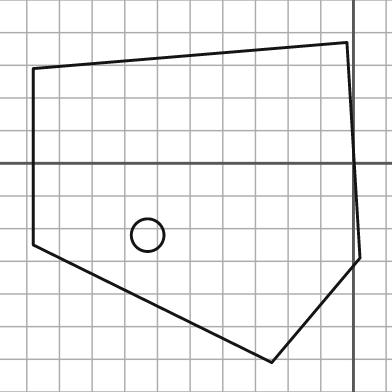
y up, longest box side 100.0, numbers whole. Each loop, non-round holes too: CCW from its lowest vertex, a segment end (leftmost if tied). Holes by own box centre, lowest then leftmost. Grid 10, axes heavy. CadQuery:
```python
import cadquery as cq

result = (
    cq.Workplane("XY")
    .moveTo(-25.0, -61.0)
    .lineTo(2.0, -29.0)
    .lineTo(-2.0, 37.0)
    .lineTo(-98.0, 29.0)
    .lineTo(-98.0, -25.0)
    .close()
    .moveTo(-63.0, -22.0)
    .circle(5.0)
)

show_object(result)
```